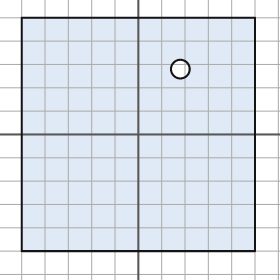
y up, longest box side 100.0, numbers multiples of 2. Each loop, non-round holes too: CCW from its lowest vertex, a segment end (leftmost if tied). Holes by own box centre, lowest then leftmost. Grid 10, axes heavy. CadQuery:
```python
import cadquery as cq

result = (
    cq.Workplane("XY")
    .moveTo(-50.0, -50.0)
    .lineTo(50.0, -50.0)
    .lineTo(50.0, 50.0)
    .lineTo(-50.0, 50.0)
    .close()
    .moveTo(18.0, 28.0)
    .circle(4.0)
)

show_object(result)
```